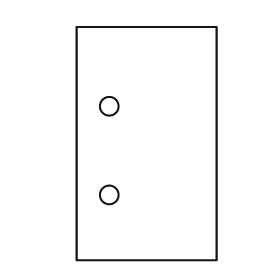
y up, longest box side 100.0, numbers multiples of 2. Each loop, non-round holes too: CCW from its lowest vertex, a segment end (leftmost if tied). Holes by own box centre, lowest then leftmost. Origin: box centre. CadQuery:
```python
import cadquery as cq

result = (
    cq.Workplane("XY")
    .moveTo(-30.0, -50.0)
    .lineTo(30.0, -50.0)
    .lineTo(30.0, 50.0)
    .lineTo(-30.0, 50.0)
    .close()
    .moveTo(-16.0, -22.0)
    .circle(4.0)
    .moveTo(-16.0, 16.0)
    .circle(4.0)
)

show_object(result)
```